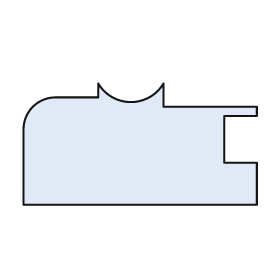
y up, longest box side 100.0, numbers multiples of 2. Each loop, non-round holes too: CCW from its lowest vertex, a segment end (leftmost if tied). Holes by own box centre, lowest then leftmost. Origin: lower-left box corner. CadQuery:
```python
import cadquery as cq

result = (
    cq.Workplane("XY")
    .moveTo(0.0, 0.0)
    .lineTo(100.0, 0.0)
    .lineTo(100.0, 18.0)
    .lineTo(86.0, 18.0)
    .lineTo(86.0, 38.0)
    .lineTo(100.0, 38.0)
    .lineTo(100.0, 42.0)
    .lineTo(60.0, 42.0)
    .lineTo(60.0, 52.0)
    .threePointArc((46.0, 44.0), (32.0, 52.0))
    .lineTo(32.0, 46.0)
    .lineTo(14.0, 46.0)
    .threePointArc((4.0, 42.0), (0.0, 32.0))
    .close()
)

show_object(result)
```